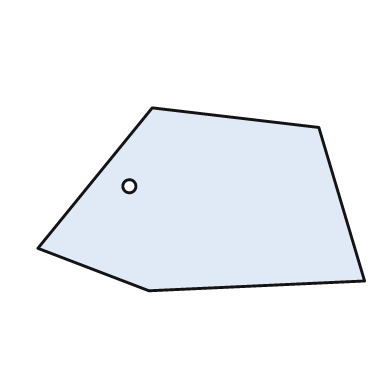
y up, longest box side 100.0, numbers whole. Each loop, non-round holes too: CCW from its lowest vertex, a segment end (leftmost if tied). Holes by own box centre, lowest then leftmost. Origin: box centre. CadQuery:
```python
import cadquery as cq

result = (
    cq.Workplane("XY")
    .moveTo(-16.0, -28.0)
    .lineTo(50.0, -25.0)
    .lineTo(36.0, 22.0)
    .lineTo(-15.0, 28.0)
    .lineTo(-50.0, -15.0)
    .close()
    .moveTo(-22.0, 4.0)
    .circle(2.0)
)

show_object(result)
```